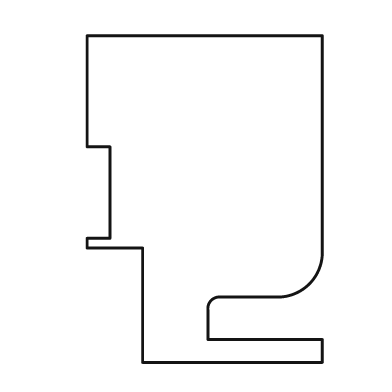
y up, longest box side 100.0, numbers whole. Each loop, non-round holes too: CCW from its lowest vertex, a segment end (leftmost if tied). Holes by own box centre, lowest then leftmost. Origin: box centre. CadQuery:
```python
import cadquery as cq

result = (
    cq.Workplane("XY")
    .moveTo(-19.0, -50.0)
    .lineTo(36.0, -50.0)
    .lineTo(36.0, -43.0)
    .lineTo(1.0, -43.0)
    .lineTo(1.0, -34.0)
    .threePointArc((2.0, -31.0), (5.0, -30.0))
    .lineTo(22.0, -30.0)
    .threePointArc((32.0, -26.0), (36.0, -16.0))
    .lineTo(36.0, 50.0)
    .lineTo(-36.0, 50.0)
    .lineTo(-36.0, 16.0)
    .lineTo(-29.0, 16.0)
    .lineTo(-29.0, -12.0)
    .lineTo(-36.0, -12.0)
    .lineTo(-36.0, -15.0)
    .lineTo(-19.0, -15.0)
    .close()
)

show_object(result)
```